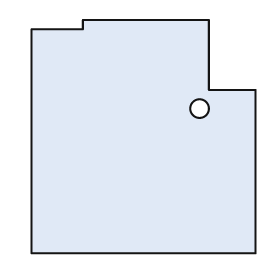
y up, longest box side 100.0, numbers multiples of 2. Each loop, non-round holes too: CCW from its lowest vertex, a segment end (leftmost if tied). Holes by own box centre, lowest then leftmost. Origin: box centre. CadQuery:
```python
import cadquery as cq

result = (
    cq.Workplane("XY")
    .moveTo(-48.0, -50.0)
    .lineTo(48.0, -50.0)
    .lineTo(48.0, 20.0)
    .lineTo(28.0, 20.0)
    .lineTo(28.0, 50.0)
    .lineTo(-26.0, 50.0)
    .lineTo(-26.0, 46.0)
    .lineTo(-48.0, 46.0)
    .close()
    .moveTo(24.0, 12.0)
    .circle(4.0)
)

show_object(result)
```